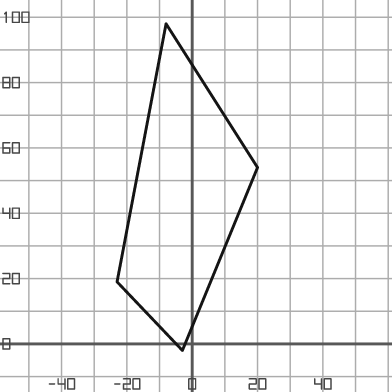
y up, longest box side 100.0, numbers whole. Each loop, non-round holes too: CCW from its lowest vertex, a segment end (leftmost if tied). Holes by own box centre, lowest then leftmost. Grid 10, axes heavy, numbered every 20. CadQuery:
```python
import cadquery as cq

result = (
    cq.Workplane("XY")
    .moveTo(-3.0, -2.0)
    .lineTo(20.0, 54.0)
    .lineTo(-8.0, 98.0)
    .lineTo(-23.0, 19.0)
    .close()
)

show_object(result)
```